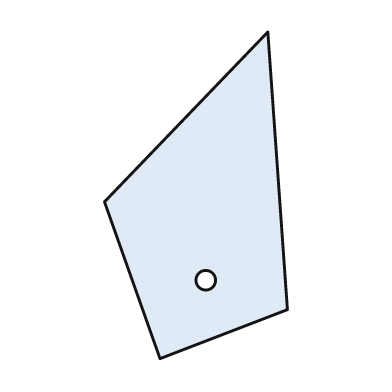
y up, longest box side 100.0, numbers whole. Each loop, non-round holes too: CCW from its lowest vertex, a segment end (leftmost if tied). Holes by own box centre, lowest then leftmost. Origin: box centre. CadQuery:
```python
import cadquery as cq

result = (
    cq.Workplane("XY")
    .moveTo(-11.0, -50.0)
    .lineTo(28.0, -35.0)
    .lineTo(22.0, 50.0)
    .lineTo(-28.0, -2.0)
    .close()
    .moveTo(3.0, -26.0)
    .circle(3.0)
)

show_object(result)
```